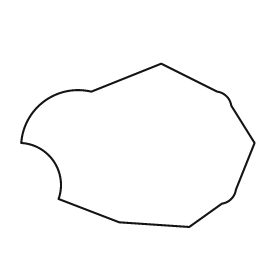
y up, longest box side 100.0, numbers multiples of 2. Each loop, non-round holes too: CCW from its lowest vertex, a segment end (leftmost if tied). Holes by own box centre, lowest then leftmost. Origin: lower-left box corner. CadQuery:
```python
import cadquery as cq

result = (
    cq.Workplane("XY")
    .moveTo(72.0, 0.0)
    .lineTo(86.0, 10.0)
    .threePointArc((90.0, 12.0), (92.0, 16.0))
    .lineTo(100.0, 36.0)
    .lineTo(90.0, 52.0)
    .threePointArc((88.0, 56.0), (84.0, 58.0))
    .lineTo(60.0, 70.0)
    .lineTo(30.0, 58.0)
    .threePointArc((10.0, 54.0), (0.0, 36.0))
    .threePointArc((14.0, 28.0), (16.0, 12.0))
    .lineTo(42.0, 2.0)
    .close()
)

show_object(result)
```